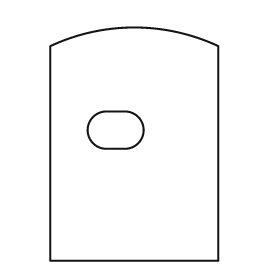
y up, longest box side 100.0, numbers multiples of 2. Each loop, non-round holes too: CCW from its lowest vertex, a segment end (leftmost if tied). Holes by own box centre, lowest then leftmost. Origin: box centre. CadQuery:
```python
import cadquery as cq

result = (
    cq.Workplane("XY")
    .moveTo(-36.0, -50.0)
    .lineTo(36.0, -50.0)
    .lineTo(36.0, 42.0)
    .threePointArc((0.0, 50.0), (-36.0, 42.0))
    .close()
    .moveTo(-12.0, -2.0)
    .lineTo(-4.0, -2.0)
    .threePointArc((4.0, 6.0), (-4.0, 14.0))
    .lineTo(-12.0, 14.0)
    .threePointArc((-20.0, 6.0), (-12.0, -2.0))
    .close()
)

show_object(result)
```